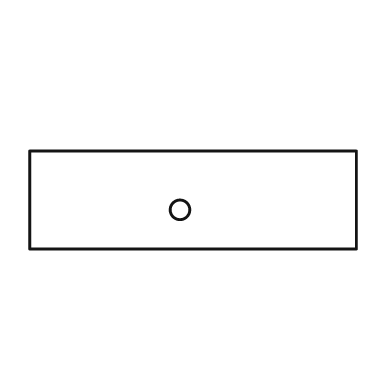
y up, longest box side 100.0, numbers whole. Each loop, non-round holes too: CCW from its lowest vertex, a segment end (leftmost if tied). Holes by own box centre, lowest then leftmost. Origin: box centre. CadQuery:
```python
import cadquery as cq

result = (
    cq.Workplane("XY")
    .moveTo(-50.0, -15.0)
    .lineTo(50.0, -15.0)
    .lineTo(50.0, 15.0)
    .lineTo(-50.0, 15.0)
    .close()
    .moveTo(-4.0, -3.0)
    .circle(3.0)
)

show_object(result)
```